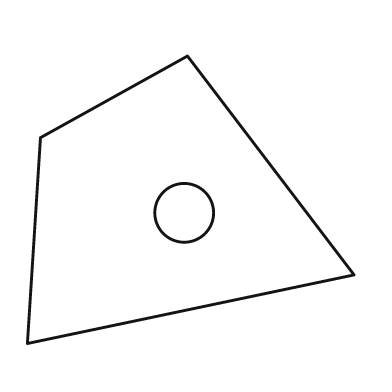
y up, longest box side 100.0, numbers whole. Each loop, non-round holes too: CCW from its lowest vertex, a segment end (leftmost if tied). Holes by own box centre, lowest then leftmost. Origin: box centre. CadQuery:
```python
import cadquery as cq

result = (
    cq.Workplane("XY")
    .moveTo(-50.0, -44.0)
    .lineTo(50.0, -23.0)
    .lineTo(-1.0, 44.0)
    .lineTo(-46.0, 19.0)
    .close()
    .moveTo(-2.0, -4.0)
    .circle(9.0)
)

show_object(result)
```